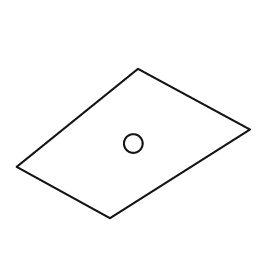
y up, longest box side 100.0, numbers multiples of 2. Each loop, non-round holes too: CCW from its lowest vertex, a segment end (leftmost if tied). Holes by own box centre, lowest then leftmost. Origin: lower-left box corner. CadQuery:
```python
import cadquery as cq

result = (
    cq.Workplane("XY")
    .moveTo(40.0, 0.0)
    .lineTo(100.0, 38.0)
    .lineTo(52.0, 64.0)
    .lineTo(0.0, 22.0)
    .close()
    .moveTo(50.0, 32.0)
    .circle(4.0)
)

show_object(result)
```